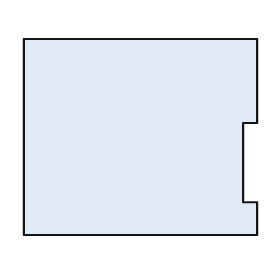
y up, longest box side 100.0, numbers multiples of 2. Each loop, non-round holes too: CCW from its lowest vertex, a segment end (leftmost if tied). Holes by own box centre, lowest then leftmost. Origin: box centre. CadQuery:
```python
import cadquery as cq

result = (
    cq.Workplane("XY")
    .moveTo(-50.0, -42.0)
    .lineTo(50.0, -42.0)
    .lineTo(50.0, -28.0)
    .lineTo(44.0, -28.0)
    .lineTo(44.0, 6.0)
    .lineTo(50.0, 6.0)
    .lineTo(50.0, 42.0)
    .lineTo(-50.0, 42.0)
    .close()
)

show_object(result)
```